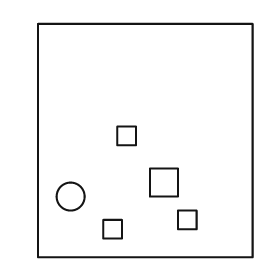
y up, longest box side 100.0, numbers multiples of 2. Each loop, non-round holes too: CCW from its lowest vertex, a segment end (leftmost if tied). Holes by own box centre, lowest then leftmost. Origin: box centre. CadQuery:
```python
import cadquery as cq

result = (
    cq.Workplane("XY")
    .moveTo(-46.0, -50.0)
    .lineTo(46.0, -50.0)
    .lineTo(46.0, 50.0)
    .lineTo(-46.0, 50.0)
    .close()
    .moveTo(-18.0, -42.0)
    .lineTo(-10.0, -42.0)
    .lineTo(-10.0, -34.0)
    .lineTo(-18.0, -34.0)
    .close()
    .moveTo(14.0, -38.0)
    .lineTo(22.0, -38.0)
    .lineTo(22.0, -30.0)
    .lineTo(14.0, -30.0)
    .close()
    .moveTo(-32.0, -24.0)
    .circle(6.0)
    .moveTo(2.0, -24.0)
    .lineTo(14.0, -24.0)
    .lineTo(14.0, -12.0)
    .lineTo(2.0, -12.0)
    .close()
    .moveTo(-12.0, -2.0)
    .lineTo(-4.0, -2.0)
    .lineTo(-4.0, 6.0)
    .lineTo(-12.0, 6.0)
    .close()
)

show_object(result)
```